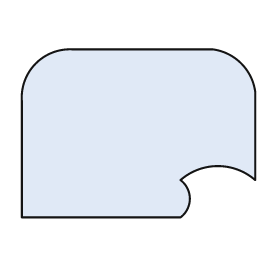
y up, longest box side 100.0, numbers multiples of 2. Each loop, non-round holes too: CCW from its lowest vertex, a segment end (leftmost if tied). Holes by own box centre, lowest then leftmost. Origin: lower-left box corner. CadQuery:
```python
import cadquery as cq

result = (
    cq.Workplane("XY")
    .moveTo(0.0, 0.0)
    .lineTo(68.0, 0.0)
    .threePointArc((72.0, 8.0), (68.0, 16.0))
    .threePointArc((84.0, 22.0), (100.0, 16.0))
    .lineTo(100.0, 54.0)
    .threePointArc((94.0, 66.0), (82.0, 72.0))
    .lineTo(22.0, 72.0)
    .threePointArc((6.0, 66.0), (0.0, 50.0))
    .close()
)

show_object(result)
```